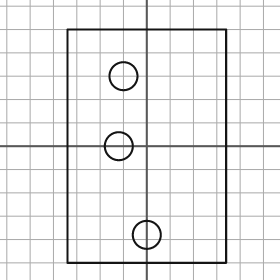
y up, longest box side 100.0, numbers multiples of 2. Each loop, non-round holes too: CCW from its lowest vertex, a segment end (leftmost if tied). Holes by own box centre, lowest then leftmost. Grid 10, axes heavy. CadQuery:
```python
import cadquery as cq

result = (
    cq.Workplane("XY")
    .moveTo(-34.0, -50.0)
    .lineTo(34.0, -50.0)
    .lineTo(34.0, 50.0)
    .lineTo(-34.0, 50.0)
    .close()
    .moveTo(0.0, -38.0)
    .circle(6.0)
    .moveTo(-12.0, 0.0)
    .circle(6.0)
    .moveTo(-10.0, 30.0)
    .circle(6.0)
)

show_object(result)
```